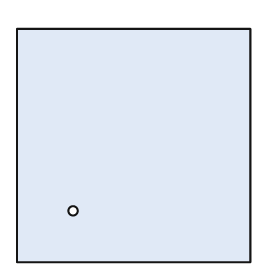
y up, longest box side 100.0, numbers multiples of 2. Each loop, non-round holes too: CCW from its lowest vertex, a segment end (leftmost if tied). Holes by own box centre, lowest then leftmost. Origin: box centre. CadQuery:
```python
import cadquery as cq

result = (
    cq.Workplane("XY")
    .moveTo(-50.0, -50.0)
    .lineTo(50.0, -50.0)
    .lineTo(50.0, 50.0)
    .lineTo(-50.0, 50.0)
    .close()
    .moveTo(-26.0, -28.0)
    .circle(2.0)
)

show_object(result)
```